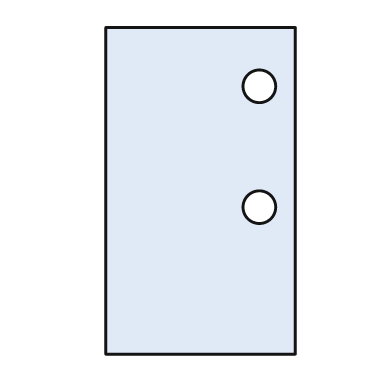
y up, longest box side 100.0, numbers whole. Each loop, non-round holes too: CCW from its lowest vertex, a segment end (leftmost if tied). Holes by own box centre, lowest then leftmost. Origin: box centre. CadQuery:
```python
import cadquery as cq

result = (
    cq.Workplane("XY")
    .moveTo(-29.0, -50.0)
    .lineTo(29.0, -50.0)
    .lineTo(29.0, 50.0)
    .lineTo(-29.0, 50.0)
    .close()
    .moveTo(18.0, -5.0)
    .circle(5.0)
    .moveTo(18.0, 32.0)
    .circle(5.0)
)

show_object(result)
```